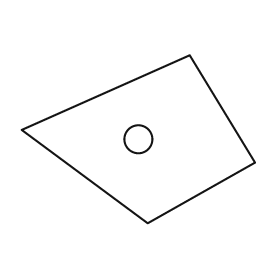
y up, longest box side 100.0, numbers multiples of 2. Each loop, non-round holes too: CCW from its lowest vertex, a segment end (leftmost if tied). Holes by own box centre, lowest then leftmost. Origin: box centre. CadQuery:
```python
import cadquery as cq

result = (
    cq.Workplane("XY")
    .moveTo(4.0, -36.0)
    .lineTo(50.0, -10.0)
    .lineTo(22.0, 36.0)
    .lineTo(-50.0, 4.0)
    .close()
    .moveTo(0.0, 0.0)
    .circle(6.0)
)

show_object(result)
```